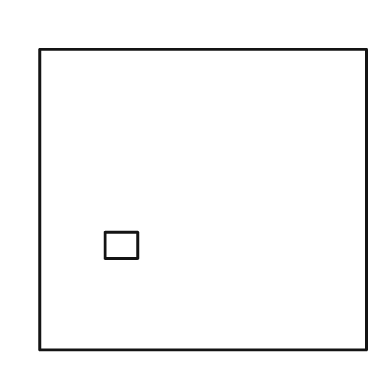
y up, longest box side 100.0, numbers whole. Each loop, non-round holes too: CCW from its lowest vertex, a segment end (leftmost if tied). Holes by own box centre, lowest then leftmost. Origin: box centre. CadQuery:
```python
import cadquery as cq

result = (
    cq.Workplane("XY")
    .moveTo(-50.0, -46.0)
    .lineTo(50.0, -46.0)
    .lineTo(50.0, 46.0)
    .lineTo(-50.0, 46.0)
    .close()
    .moveTo(-30.0, -18.0)
    .lineTo(-20.0, -18.0)
    .lineTo(-20.0, -10.0)
    .lineTo(-30.0, -10.0)
    .close()
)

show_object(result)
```